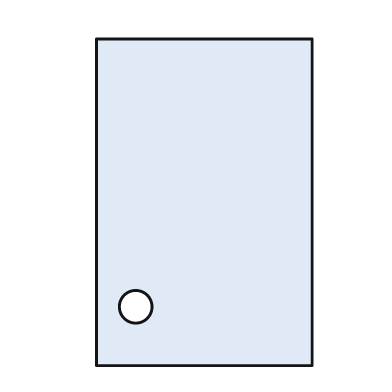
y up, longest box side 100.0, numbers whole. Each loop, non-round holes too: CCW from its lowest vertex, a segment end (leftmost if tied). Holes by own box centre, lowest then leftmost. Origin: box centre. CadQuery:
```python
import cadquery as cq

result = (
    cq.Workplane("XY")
    .moveTo(-33.0, -50.0)
    .lineTo(33.0, -50.0)
    .lineTo(33.0, 50.0)
    .lineTo(-33.0, 50.0)
    .close()
    .moveTo(-21.0, -32.0)
    .circle(5.0)
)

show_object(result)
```